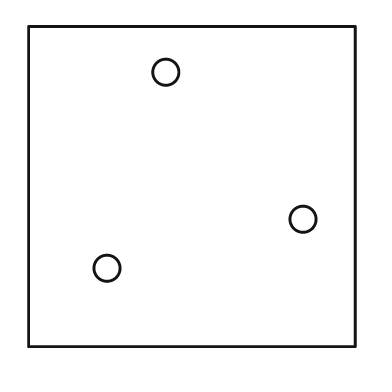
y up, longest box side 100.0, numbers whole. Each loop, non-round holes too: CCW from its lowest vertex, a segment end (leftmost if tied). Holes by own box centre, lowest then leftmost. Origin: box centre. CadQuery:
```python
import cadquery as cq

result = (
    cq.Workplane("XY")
    .moveTo(-50.0, -49.0)
    .lineTo(50.0, -49.0)
    .lineTo(50.0, 49.0)
    .lineTo(-50.0, 49.0)
    .close()
    .moveTo(-26.0, -25.0)
    .circle(4.0)
    .moveTo(34.0, -10.0)
    .circle(4.0)
    .moveTo(-8.0, 35.0)
    .circle(4.0)
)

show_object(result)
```